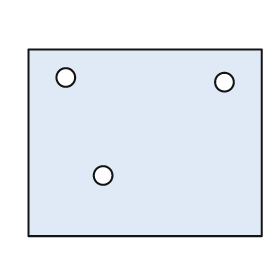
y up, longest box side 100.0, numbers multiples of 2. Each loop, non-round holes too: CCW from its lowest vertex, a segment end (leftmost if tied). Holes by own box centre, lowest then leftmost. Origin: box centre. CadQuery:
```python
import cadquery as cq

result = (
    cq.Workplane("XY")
    .moveTo(-50.0, -40.0)
    .lineTo(50.0, -40.0)
    .lineTo(50.0, 40.0)
    .lineTo(-50.0, 40.0)
    .close()
    .moveTo(-18.0, -14.0)
    .circle(4.0)
    .moveTo(34.0, 26.0)
    .circle(4.0)
    .moveTo(-34.0, 28.0)
    .circle(4.0)
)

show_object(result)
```